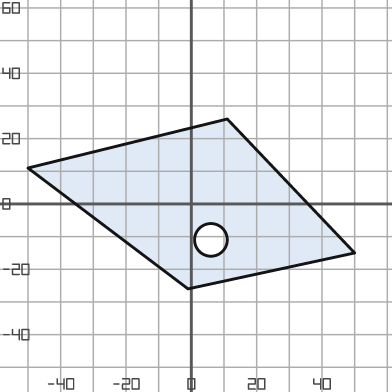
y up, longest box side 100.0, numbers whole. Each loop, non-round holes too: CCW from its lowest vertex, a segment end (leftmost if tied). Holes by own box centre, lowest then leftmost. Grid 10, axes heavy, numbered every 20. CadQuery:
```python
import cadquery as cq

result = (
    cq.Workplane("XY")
    .moveTo(-1.0, -26.0)
    .lineTo(50.0, -15.0)
    .lineTo(11.0, 26.0)
    .lineTo(-50.0, 11.0)
    .close()
    .moveTo(6.0, -11.0)
    .circle(5.0)
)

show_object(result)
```